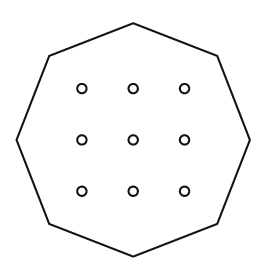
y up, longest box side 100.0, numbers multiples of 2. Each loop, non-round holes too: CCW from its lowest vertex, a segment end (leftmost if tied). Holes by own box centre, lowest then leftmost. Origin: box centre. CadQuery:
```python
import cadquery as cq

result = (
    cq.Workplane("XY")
    .moveTo(0.0, -50.0)
    .lineTo(36.0, -36.0)
    .lineTo(50.0, 0.0)
    .lineTo(36.0, 36.0)
    .lineTo(0.0, 50.0)
    .lineTo(-36.0, 36.0)
    .lineTo(-50.0, 0.0)
    .lineTo(-36.0, -36.0)
    .close()
    .moveTo(-22.0, -22.0)
    .circle(2.0)
    .moveTo(0.0, -22.0)
    .circle(2.0)
    .moveTo(22.0, -22.0)
    .circle(2.0)
    .moveTo(-22.0, 0.0)
    .circle(2.0)
    .moveTo(0.0, 0.0)
    .circle(2.0)
    .moveTo(22.0, 0.0)
    .circle(2.0)
    .moveTo(-22.0, 22.0)
    .circle(2.0)
    .moveTo(0.0, 22.0)
    .circle(2.0)
    .moveTo(22.0, 22.0)
    .circle(2.0)
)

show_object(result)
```